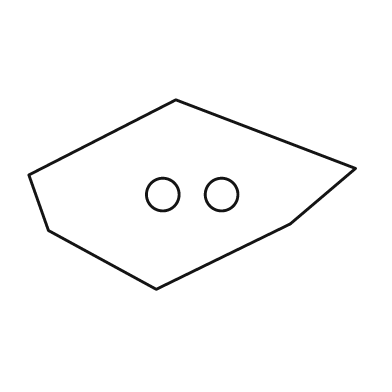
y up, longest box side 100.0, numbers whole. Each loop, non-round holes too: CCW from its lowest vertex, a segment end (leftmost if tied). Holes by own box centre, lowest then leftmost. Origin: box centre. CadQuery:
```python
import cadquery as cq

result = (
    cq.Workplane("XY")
    .moveTo(-11.0, -29.0)
    .lineTo(30.0, -9.0)
    .lineTo(50.0, 8.0)
    .lineTo(-5.0, 29.0)
    .lineTo(-50.0, 6.0)
    .lineTo(-44.0, -11.0)
    .close()
    .moveTo(-9.0, 0.0)
    .circle(5.0)
    .moveTo(9.0, 0.0)
    .circle(5.0)
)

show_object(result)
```